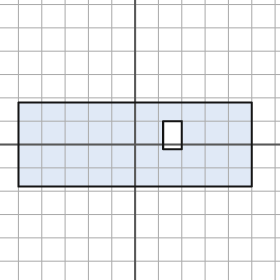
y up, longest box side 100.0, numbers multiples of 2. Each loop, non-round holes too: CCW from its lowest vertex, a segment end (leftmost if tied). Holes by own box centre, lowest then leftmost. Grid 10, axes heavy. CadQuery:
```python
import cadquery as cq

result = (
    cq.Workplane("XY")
    .moveTo(-50.0, -18.0)
    .lineTo(50.0, -18.0)
    .lineTo(50.0, 18.0)
    .lineTo(-50.0, 18.0)
    .close()
    .moveTo(12.0, -2.0)
    .lineTo(20.0, -2.0)
    .lineTo(20.0, 10.0)
    .lineTo(12.0, 10.0)
    .close()
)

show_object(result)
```